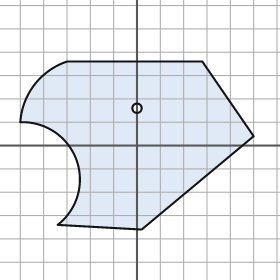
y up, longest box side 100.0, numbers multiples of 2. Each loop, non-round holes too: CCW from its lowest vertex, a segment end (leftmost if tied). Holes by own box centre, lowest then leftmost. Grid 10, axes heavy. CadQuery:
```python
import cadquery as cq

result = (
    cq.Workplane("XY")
    .moveTo(2.0, -36.0)
    .lineTo(50.0, 4.0)
    .lineTo(28.0, 36.0)
    .lineTo(-30.0, 36.0)
    .threePointArc((-44.0, 26.0), (-50.0, 10.0))
    .threePointArc((-26.0, -6.0), (-34.0, -34.0))
    .close()
    .moveTo(0.0, 16.0)
    .circle(2.0)
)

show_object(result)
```